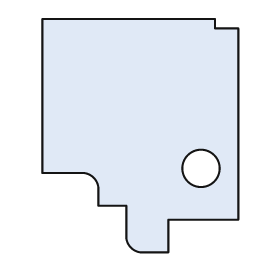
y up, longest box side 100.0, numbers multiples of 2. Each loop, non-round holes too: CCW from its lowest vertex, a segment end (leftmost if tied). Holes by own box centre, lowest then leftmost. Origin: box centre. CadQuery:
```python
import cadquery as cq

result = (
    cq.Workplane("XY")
    .moveTo(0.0, -50.0)
    .lineTo(12.0, -50.0)
    .lineTo(12.0, -36.0)
    .lineTo(42.0, -36.0)
    .lineTo(42.0, 46.0)
    .lineTo(32.0, 46.0)
    .lineTo(32.0, 50.0)
    .lineTo(-42.0, 50.0)
    .lineTo(-42.0, -16.0)
    .lineTo(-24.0, -16.0)
    .threePointArc((-20.0, -18.0), (-18.0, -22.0))
    .lineTo(-18.0, -30.0)
    .lineTo(-6.0, -30.0)
    .lineTo(-6.0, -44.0)
    .threePointArc((-4.0, -48.0), (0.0, -50.0))
    .close()
    .moveTo(26.0, -14.0)
    .circle(8.0)
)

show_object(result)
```